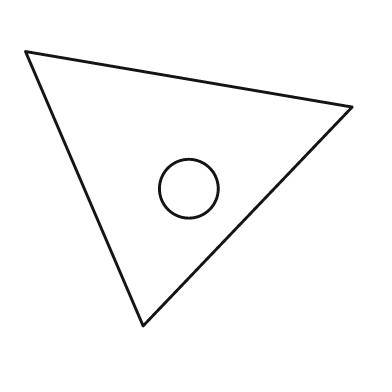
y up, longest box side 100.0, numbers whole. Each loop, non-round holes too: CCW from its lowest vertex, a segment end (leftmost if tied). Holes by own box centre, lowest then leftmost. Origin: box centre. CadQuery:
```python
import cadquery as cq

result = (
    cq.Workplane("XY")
    .moveTo(-14.0, -42.0)
    .lineTo(50.0, 25.0)
    .lineTo(-50.0, 42.0)
    .close()
    .moveTo(0.0, 0.0)
    .circle(9.0)
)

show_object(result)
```